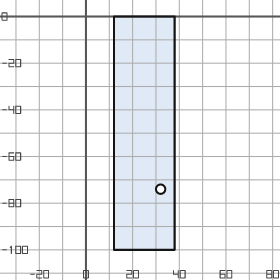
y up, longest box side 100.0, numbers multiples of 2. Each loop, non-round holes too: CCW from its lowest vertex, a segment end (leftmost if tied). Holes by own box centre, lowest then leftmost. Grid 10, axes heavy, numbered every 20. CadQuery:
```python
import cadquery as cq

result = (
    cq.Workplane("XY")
    .moveTo(12.0, -100.0)
    .lineTo(38.0, -100.0)
    .lineTo(38.0, 0.0)
    .lineTo(12.0, 0.0)
    .close()
    .moveTo(32.0, -74.0)
    .circle(2.0)
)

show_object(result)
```